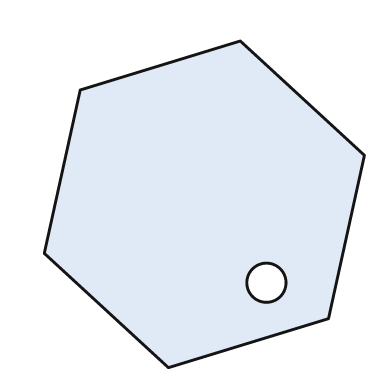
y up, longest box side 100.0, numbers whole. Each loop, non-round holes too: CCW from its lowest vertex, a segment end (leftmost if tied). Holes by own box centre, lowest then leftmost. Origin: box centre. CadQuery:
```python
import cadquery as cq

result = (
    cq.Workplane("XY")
    .moveTo(-11.0, -50.0)
    .lineTo(38.0, -35.0)
    .lineTo(49.0, 15.0)
    .lineTo(11.0, 50.0)
    .lineTo(-38.0, 35.0)
    .lineTo(-49.0, -15.0)
    .close()
    .moveTo(19.0, -24.0)
    .circle(6.0)
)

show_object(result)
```